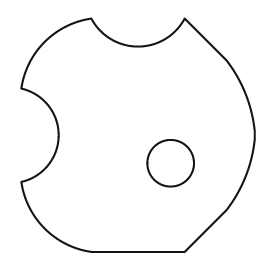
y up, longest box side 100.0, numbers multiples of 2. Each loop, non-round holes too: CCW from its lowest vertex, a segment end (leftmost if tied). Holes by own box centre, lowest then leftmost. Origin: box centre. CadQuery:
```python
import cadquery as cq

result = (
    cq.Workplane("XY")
    .moveTo(-20.0, -50.0)
    .lineTo(20.0, -50.0)
    .lineTo(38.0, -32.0)
    .threePointArc((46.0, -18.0), (50.0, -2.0))
    .lineTo(50.0, 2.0)
    .threePointArc((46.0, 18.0), (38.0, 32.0))
    .lineTo(20.0, 50.0)
    .threePointArc((0.0, 38.0), (-20.0, 50.0))
    .threePointArc((-40.0, 40.0), (-50.0, 20.0))
    .threePointArc((-34.0, 0.0), (-50.0, -20.0))
    .threePointArc((-40.0, -40.0), (-20.0, -50.0))
    .close()
    .moveTo(14.0, -12.0)
    .circle(10.0)
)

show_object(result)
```